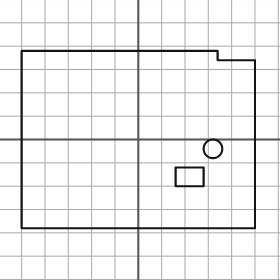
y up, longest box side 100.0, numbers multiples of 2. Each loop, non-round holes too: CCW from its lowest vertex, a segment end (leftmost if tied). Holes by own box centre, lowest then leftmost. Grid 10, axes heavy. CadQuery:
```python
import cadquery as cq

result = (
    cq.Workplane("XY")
    .moveTo(-50.0, -38.0)
    .lineTo(50.0, -38.0)
    .lineTo(50.0, 34.0)
    .lineTo(34.0, 34.0)
    .lineTo(34.0, 38.0)
    .lineTo(-50.0, 38.0)
    .close()
    .moveTo(16.0, -20.0)
    .lineTo(28.0, -20.0)
    .lineTo(28.0, -12.0)
    .lineTo(16.0, -12.0)
    .close()
    .moveTo(32.0, -4.0)
    .circle(4.0)
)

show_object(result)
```